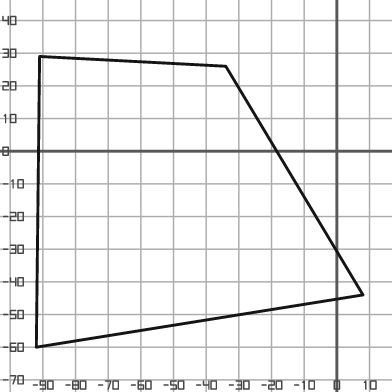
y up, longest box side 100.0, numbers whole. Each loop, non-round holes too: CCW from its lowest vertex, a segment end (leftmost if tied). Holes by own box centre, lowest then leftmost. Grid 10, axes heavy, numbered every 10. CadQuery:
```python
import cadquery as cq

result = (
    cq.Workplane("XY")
    .moveTo(-92.0, -60.0)
    .lineTo(8.0, -44.0)
    .lineTo(-34.0, 26.0)
    .lineTo(-91.0, 29.0)
    .close()
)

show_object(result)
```